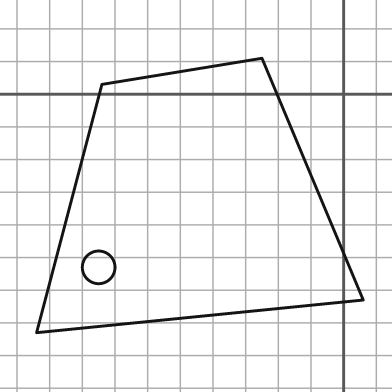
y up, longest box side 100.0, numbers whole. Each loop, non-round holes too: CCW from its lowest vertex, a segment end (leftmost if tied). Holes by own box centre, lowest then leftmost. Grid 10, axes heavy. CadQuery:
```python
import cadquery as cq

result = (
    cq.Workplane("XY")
    .moveTo(-94.0, -73.0)
    .lineTo(6.0, -63.0)
    .lineTo(-25.0, 11.0)
    .lineTo(-74.0, 3.0)
    .close()
    .moveTo(-75.0, -53.0)
    .circle(5.0)
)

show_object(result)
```